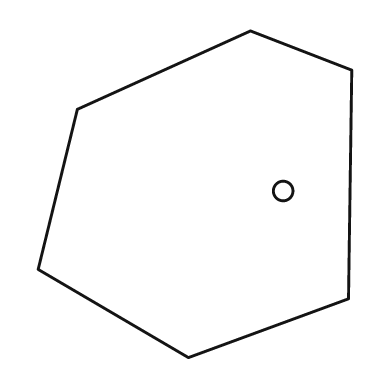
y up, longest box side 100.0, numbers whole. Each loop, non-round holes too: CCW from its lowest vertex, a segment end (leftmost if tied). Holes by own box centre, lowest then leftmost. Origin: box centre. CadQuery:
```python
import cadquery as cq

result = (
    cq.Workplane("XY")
    .moveTo(-2.0, -50.0)
    .lineTo(47.0, -32.0)
    .lineTo(48.0, 38.0)
    .lineTo(17.0, 50.0)
    .lineTo(-36.0, 26.0)
    .lineTo(-48.0, -23.0)
    .close()
    .moveTo(27.0, 1.0)
    .circle(3.0)
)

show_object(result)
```